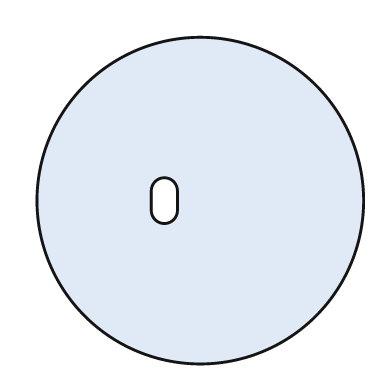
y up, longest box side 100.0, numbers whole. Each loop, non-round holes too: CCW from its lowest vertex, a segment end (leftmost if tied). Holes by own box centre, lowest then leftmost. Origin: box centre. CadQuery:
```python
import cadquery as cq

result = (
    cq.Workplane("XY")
    .moveTo(0.0, 0.0)
    .circle(50.0)
    .moveTo(-15.0, -3.0)
    .threePointArc((-11.0, -7.0), (-7.0, -3.0))
    .lineTo(-7.0, 3.0)
    .threePointArc((-11.0, 7.0), (-15.0, 3.0))
    .close()
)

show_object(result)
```